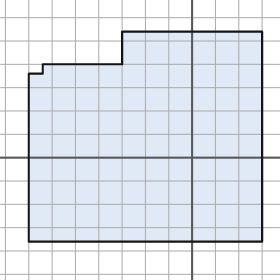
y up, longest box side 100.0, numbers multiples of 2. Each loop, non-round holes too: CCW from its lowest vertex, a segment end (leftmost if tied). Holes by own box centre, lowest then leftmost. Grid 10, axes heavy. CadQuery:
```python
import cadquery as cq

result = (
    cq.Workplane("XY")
    .moveTo(-70.0, -36.0)
    .lineTo(30.0, -36.0)
    .lineTo(30.0, 54.0)
    .lineTo(-30.0, 54.0)
    .lineTo(-30.0, 40.0)
    .lineTo(-64.0, 40.0)
    .lineTo(-64.0, 36.0)
    .lineTo(-70.0, 36.0)
    .close()
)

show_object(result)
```